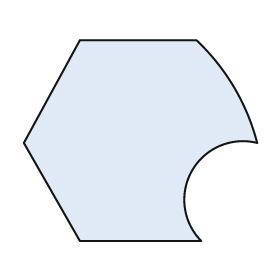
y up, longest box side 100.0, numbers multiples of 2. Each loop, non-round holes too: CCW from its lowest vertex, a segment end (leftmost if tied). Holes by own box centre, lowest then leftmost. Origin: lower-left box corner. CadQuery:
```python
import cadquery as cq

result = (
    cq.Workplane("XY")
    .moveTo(24.0, 0.0)
    .lineTo(76.0, 0.0)
    .threePointArc((72.0, 30.0), (100.0, 42.0))
    .threePointArc((90.0, 66.0), (74.0, 86.0))
    .lineTo(24.0, 86.0)
    .lineTo(0.0, 42.0)
    .close()
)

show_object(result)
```